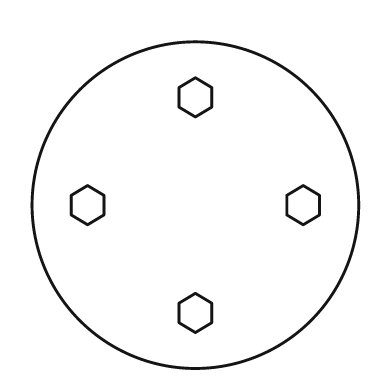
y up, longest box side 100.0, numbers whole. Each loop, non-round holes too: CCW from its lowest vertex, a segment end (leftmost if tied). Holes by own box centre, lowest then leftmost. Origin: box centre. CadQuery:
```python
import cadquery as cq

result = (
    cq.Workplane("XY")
    .moveTo(0.0, 0.0)
    .circle(50.0)
    .moveTo(0.0, -39.0)
    .lineTo(5.0, -36.0)
    .lineTo(5.0, -30.0)
    .lineTo(0.0, -27.0)
    .lineTo(-5.0, -30.0)
    .lineTo(-5.0, -36.0)
    .close()
    .moveTo(-33.0, -6.0)
    .lineTo(-28.0, -3.0)
    .lineTo(-28.0, 3.0)
    .lineTo(-33.0, 6.0)
    .lineTo(-38.0, 3.0)
    .lineTo(-38.0, -3.0)
    .close()
    .moveTo(33.0, -6.0)
    .lineTo(38.0, -3.0)
    .lineTo(38.0, 3.0)
    .lineTo(33.0, 6.0)
    .lineTo(28.0, 3.0)
    .lineTo(28.0, -3.0)
    .close()
    .moveTo(0.0, 27.0)
    .lineTo(5.0, 30.0)
    .lineTo(5.0, 36.0)
    .lineTo(0.0, 39.0)
    .lineTo(-5.0, 36.0)
    .lineTo(-5.0, 30.0)
    .close()
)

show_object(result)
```